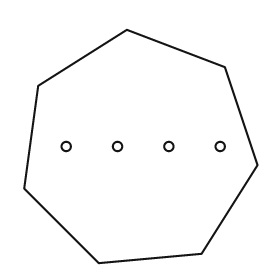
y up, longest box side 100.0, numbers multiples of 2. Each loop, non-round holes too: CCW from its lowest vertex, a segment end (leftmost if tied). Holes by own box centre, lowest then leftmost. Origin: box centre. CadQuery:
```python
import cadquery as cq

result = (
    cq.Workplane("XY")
    .moveTo(-18.0, -50.0)
    .lineTo(26.0, -46.0)
    .lineTo(50.0, -8.0)
    .lineTo(36.0, 34.0)
    .lineTo(-6.0, 50.0)
    .lineTo(-44.0, 26.0)
    .lineTo(-50.0, -18.0)
    .close()
    .moveTo(-32.0, 0.0)
    .circle(2.0)
    .moveTo(-10.0, 0.0)
    .circle(2.0)
    .moveTo(12.0, 0.0)
    .circle(2.0)
    .moveTo(34.0, 0.0)
    .circle(2.0)
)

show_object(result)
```